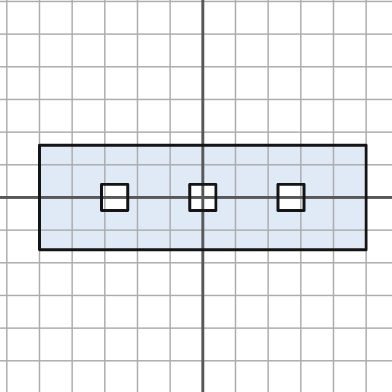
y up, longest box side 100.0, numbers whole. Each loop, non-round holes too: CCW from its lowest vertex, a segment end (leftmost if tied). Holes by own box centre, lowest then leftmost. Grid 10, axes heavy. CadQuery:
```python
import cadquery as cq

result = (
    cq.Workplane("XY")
    .moveTo(-50.0, -16.0)
    .lineTo(50.0, -16.0)
    .lineTo(50.0, 16.0)
    .lineTo(-50.0, 16.0)
    .close()
    .moveTo(-31.0, -4.0)
    .lineTo(-23.0, -4.0)
    .lineTo(-23.0, 4.0)
    .lineTo(-31.0, 4.0)
    .close()
    .moveTo(-4.0, -4.0)
    .lineTo(4.0, -4.0)
    .lineTo(4.0, 4.0)
    .lineTo(-4.0, 4.0)
    .close()
    .moveTo(23.0, -4.0)
    .lineTo(31.0, -4.0)
    .lineTo(31.0, 4.0)
    .lineTo(23.0, 4.0)
    .close()
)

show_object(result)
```